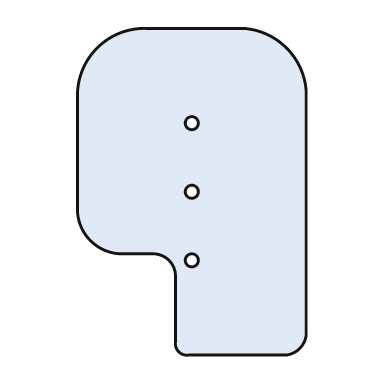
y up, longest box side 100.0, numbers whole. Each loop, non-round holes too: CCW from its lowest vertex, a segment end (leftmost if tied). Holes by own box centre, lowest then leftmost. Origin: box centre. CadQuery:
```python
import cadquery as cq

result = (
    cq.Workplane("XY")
    .moveTo(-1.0, -50.0)
    .lineTo(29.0, -50.0)
    .threePointArc((33.0, -48.0), (35.0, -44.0))
    .lineTo(35.0, 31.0)
    .threePointArc((29.0, 44.0), (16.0, 50.0))
    .lineTo(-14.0, 50.0)
    .threePointArc((-29.0, 44.0), (-35.0, 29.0))
    .lineTo(-35.0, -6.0)
    .threePointArc((-31.0, -15.0), (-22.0, -19.0))
    .lineTo(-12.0, -19.0)
    .threePointArc((-7.0, -21.0), (-5.0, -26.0))
    .lineTo(-5.0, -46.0)
    .threePointArc((-4.0, -49.0), (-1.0, -50.0))
    .close()
    .moveTo(0.0, -21.0)
    .circle(2.0)
    .moveTo(0.0, 0.0)
    .circle(2.0)
    .moveTo(0.0, 21.0)
    .circle(2.0)
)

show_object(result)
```